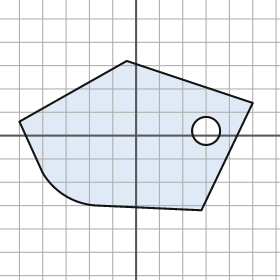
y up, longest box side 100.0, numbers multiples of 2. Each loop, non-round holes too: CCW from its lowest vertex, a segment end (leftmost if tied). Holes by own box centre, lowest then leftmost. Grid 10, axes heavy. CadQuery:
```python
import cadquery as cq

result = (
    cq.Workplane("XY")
    .moveTo(28.0, -32.0)
    .lineTo(50.0, 14.0)
    .lineTo(-4.0, 32.0)
    .lineTo(-50.0, 6.0)
    .lineTo(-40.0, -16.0)
    .threePointArc((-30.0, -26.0), (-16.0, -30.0))
    .close()
    .moveTo(30.0, 2.0)
    .circle(6.0)
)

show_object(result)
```